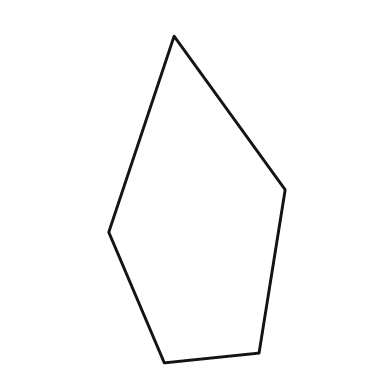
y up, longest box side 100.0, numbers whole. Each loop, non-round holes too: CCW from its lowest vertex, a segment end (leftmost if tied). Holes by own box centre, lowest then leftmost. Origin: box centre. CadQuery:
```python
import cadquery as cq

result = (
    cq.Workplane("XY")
    .moveTo(-10.0, -50.0)
    .lineTo(19.0, -47.0)
    .lineTo(27.0, 3.0)
    .lineTo(-7.0, 50.0)
    .lineTo(-27.0, -10.0)
    .close()
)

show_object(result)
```